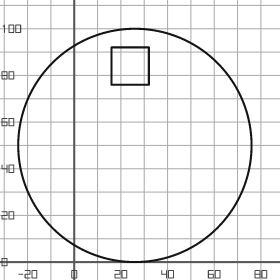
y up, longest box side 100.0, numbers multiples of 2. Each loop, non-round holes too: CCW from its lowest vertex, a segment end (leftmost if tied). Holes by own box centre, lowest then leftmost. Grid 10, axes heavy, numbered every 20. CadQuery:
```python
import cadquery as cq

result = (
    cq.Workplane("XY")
    .moveTo(26.0, 50.0)
    .circle(50.0)
    .moveTo(16.0, 76.0)
    .lineTo(32.0, 76.0)
    .lineTo(32.0, 92.0)
    .lineTo(16.0, 92.0)
    .close()
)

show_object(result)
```